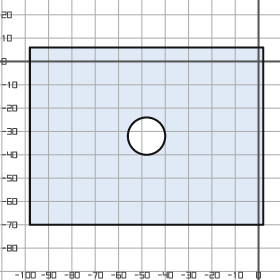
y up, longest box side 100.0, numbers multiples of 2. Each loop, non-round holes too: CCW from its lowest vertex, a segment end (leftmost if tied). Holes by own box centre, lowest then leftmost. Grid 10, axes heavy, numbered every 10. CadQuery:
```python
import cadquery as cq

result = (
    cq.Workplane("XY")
    .moveTo(-98.0, -70.0)
    .lineTo(2.0, -70.0)
    .lineTo(2.0, 6.0)
    .lineTo(-98.0, 6.0)
    .close()
    .moveTo(-48.0, -32.0)
    .circle(8.0)
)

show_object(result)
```